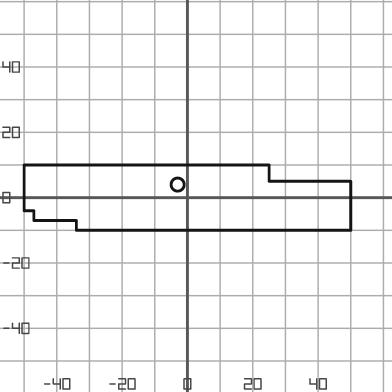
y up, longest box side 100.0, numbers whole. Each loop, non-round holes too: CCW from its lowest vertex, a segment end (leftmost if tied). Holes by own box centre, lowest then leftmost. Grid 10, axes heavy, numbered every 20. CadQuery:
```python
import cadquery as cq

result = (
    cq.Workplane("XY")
    .moveTo(-34.0, -10.0)
    .lineTo(50.0, -10.0)
    .lineTo(50.0, 5.0)
    .lineTo(25.0, 5.0)
    .lineTo(25.0, 10.0)
    .lineTo(-50.0, 10.0)
    .lineTo(-50.0, -4.0)
    .lineTo(-47.0, -4.0)
    .lineTo(-47.0, -7.0)
    .lineTo(-34.0, -7.0)
    .close()
    .moveTo(-3.0, 4.0)
    .circle(2.0)
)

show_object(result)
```